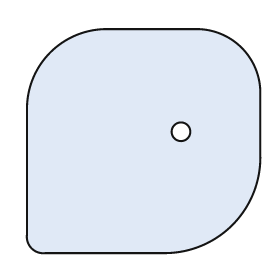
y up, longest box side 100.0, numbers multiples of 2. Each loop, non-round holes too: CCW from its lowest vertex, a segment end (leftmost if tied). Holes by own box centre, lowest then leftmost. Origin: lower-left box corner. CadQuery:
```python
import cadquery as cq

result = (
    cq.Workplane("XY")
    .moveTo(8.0, 0.0)
    .lineTo(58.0, 0.0)
    .threePointArc((88.0, 12.0), (100.0, 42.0))
    .lineTo(100.0, 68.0)
    .threePointArc((92.0, 88.0), (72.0, 96.0))
    .lineTo(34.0, 96.0)
    .threePointArc((10.0, 86.0), (0.0, 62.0))
    .lineTo(0.0, 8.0)
    .threePointArc((2.0, 2.0), (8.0, 0.0))
    .close()
    .moveTo(66.0, 52.0)
    .circle(4.0)
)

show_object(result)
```